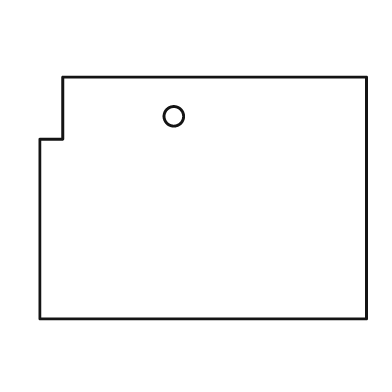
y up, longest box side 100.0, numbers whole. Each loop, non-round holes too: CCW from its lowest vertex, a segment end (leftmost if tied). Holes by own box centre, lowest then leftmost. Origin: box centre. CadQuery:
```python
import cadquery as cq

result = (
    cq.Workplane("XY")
    .moveTo(-50.0, -37.0)
    .lineTo(50.0, -37.0)
    .lineTo(50.0, 37.0)
    .lineTo(-43.0, 37.0)
    .lineTo(-43.0, 18.0)
    .lineTo(-50.0, 18.0)
    .close()
    .moveTo(-9.0, 25.0)
    .circle(3.0)
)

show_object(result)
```